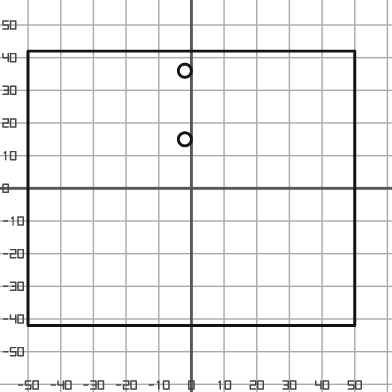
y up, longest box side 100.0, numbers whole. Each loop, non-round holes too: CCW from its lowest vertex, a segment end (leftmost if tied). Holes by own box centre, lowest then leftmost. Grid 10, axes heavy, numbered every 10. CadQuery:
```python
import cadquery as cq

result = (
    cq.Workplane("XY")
    .moveTo(-50.0, -42.0)
    .lineTo(50.0, -42.0)
    .lineTo(50.0, 42.0)
    .lineTo(-50.0, 42.0)
    .close()
    .moveTo(-2.0, 15.0)
    .circle(2.0)
    .moveTo(-2.0, 36.0)
    .circle(2.0)
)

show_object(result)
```